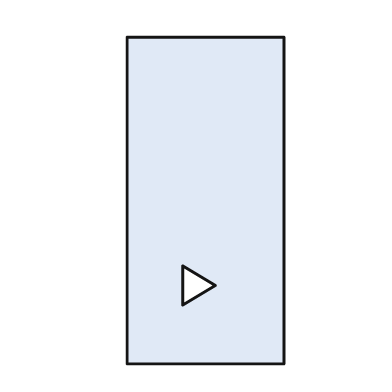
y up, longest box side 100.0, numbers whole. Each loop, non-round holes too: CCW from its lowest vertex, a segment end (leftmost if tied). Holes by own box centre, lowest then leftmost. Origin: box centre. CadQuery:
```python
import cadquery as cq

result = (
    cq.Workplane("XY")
    .moveTo(-24.0, -50.0)
    .lineTo(24.0, -50.0)
    .lineTo(24.0, 50.0)
    .lineTo(-24.0, 50.0)
    .close()
    .moveTo(-7.0, -32.0)
    .lineTo(3.0, -26.0)
    .lineTo(-7.0, -20.0)
    .close()
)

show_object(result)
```